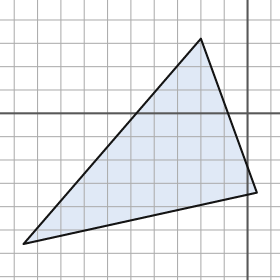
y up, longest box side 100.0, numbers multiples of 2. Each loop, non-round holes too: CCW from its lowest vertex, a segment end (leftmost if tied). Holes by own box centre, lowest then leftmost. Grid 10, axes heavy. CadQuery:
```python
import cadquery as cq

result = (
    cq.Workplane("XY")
    .moveTo(-96.0, -56.0)
    .lineTo(4.0, -34.0)
    .lineTo(-20.0, 32.0)
    .close()
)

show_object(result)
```